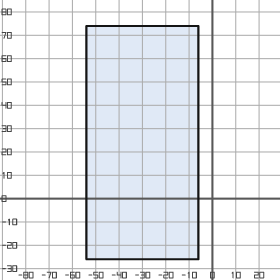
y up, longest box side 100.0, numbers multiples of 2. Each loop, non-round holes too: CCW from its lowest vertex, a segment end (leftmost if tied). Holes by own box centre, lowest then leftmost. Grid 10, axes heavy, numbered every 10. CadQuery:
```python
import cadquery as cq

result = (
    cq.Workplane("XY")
    .moveTo(-54.0, -26.0)
    .lineTo(-6.0, -26.0)
    .lineTo(-6.0, 74.0)
    .lineTo(-54.0, 74.0)
    .close()
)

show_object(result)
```